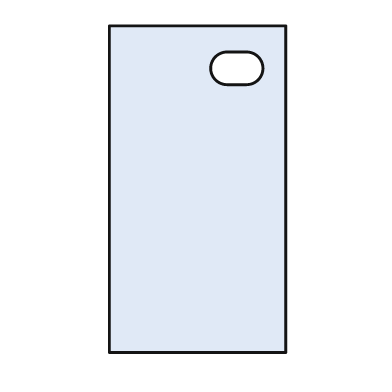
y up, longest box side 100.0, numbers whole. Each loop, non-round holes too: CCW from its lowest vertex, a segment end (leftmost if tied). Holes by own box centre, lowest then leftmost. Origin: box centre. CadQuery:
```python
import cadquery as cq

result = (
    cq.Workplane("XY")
    .moveTo(-27.0, -50.0)
    .lineTo(27.0, -50.0)
    .lineTo(27.0, 50.0)
    .lineTo(-27.0, 50.0)
    .close()
    .moveTo(9.0, 32.0)
    .lineTo(15.0, 32.0)
    .threePointArc((20.0, 37.0), (15.0, 42.0))
    .lineTo(9.0, 42.0)
    .threePointArc((4.0, 37.0), (9.0, 32.0))
    .close()
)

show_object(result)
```